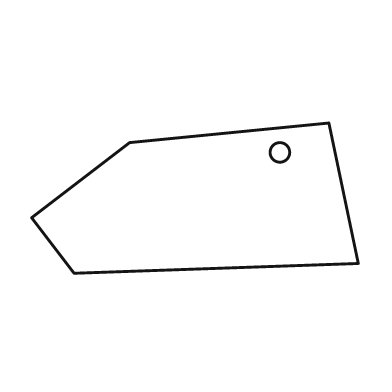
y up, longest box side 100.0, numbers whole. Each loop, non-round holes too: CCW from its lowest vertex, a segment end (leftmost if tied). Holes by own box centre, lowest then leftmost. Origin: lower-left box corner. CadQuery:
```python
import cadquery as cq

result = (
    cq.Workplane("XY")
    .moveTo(13.0, 0.0)
    .lineTo(100.0, 3.0)
    .lineTo(91.0, 46.0)
    .lineTo(30.0, 40.0)
    .lineTo(0.0, 17.0)
    .close()
    .moveTo(76.0, 37.0)
    .circle(3.0)
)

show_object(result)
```